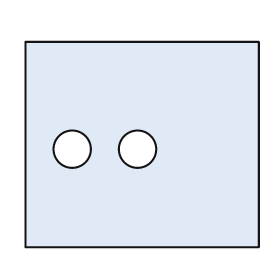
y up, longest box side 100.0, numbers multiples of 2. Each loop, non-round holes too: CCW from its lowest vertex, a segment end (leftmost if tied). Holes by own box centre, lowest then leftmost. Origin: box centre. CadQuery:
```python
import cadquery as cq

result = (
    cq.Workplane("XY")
    .moveTo(-50.0, -44.0)
    .lineTo(50.0, -44.0)
    .lineTo(50.0, 44.0)
    .lineTo(-50.0, 44.0)
    .close()
    .moveTo(-30.0, -2.0)
    .circle(8.0)
    .moveTo(-2.0, -2.0)
    .circle(8.0)
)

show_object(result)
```